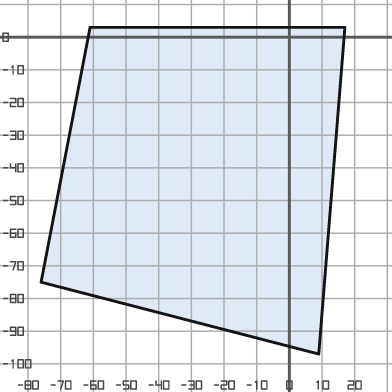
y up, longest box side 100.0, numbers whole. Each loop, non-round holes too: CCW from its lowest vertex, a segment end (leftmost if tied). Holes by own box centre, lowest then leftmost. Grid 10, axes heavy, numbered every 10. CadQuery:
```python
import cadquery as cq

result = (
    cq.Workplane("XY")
    .moveTo(9.0, -97.0)
    .lineTo(17.0, 3.0)
    .lineTo(-61.0, 3.0)
    .lineTo(-76.0, -75.0)
    .close()
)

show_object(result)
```